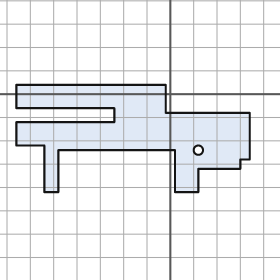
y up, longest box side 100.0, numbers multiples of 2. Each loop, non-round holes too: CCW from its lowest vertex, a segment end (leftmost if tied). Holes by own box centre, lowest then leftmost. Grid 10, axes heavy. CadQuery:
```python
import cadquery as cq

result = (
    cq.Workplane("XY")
    .moveTo(-54.0, -42.0)
    .lineTo(-48.0, -42.0)
    .lineTo(-48.0, -24.0)
    .lineTo(2.0, -24.0)
    .lineTo(2.0, -42.0)
    .lineTo(12.0, -42.0)
    .lineTo(12.0, -32.0)
    .lineTo(30.0, -32.0)
    .lineTo(30.0, -28.0)
    .lineTo(34.0, -28.0)
    .lineTo(34.0, -8.0)
    .lineTo(-2.0, -8.0)
    .lineTo(-2.0, 4.0)
    .lineTo(-66.0, 4.0)
    .lineTo(-66.0, -6.0)
    .lineTo(-24.0, -6.0)
    .lineTo(-24.0, -12.0)
    .lineTo(-66.0, -12.0)
    .lineTo(-66.0, -22.0)
    .lineTo(-54.0, -22.0)
    .close()
    .moveTo(12.0, -24.0)
    .circle(2.0)
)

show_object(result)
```